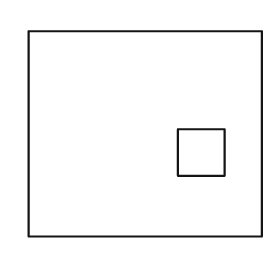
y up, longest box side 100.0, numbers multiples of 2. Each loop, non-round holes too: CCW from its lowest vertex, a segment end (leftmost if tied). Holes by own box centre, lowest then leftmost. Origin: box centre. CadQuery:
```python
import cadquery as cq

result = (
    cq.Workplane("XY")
    .moveTo(-50.0, -44.0)
    .lineTo(50.0, -44.0)
    .lineTo(50.0, 44.0)
    .lineTo(-50.0, 44.0)
    .close()
    .moveTo(14.0, -18.0)
    .lineTo(34.0, -18.0)
    .lineTo(34.0, 2.0)
    .lineTo(14.0, 2.0)
    .close()
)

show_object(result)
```